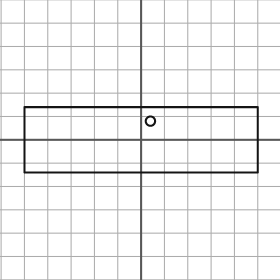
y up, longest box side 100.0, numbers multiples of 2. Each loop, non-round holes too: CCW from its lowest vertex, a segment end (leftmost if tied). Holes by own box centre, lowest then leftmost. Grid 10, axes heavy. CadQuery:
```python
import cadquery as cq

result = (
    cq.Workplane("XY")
    .moveTo(-50.0, -14.0)
    .lineTo(50.0, -14.0)
    .lineTo(50.0, 14.0)
    .lineTo(-50.0, 14.0)
    .close()
    .moveTo(4.0, 8.0)
    .circle(2.0)
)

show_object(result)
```